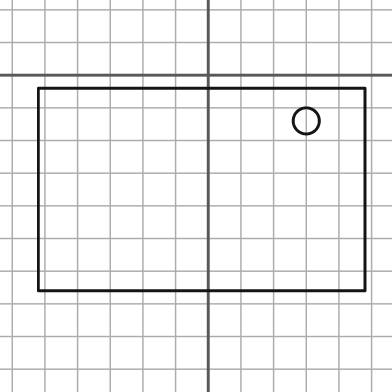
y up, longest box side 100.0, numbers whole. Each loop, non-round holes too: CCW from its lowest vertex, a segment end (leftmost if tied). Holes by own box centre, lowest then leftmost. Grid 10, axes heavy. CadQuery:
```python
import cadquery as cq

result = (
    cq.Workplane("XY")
    .moveTo(-52.0, -66.0)
    .lineTo(48.0, -66.0)
    .lineTo(48.0, -4.0)
    .lineTo(-52.0, -4.0)
    .close()
    .moveTo(30.0, -14.0)
    .circle(4.0)
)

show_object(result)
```